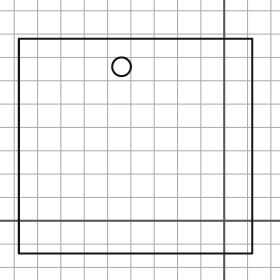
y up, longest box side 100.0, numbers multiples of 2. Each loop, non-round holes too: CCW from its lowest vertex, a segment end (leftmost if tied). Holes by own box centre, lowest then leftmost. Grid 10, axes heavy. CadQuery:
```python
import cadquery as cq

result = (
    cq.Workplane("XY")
    .moveTo(-88.0, -14.0)
    .lineTo(12.0, -14.0)
    .lineTo(12.0, 78.0)
    .lineTo(-88.0, 78.0)
    .close()
    .moveTo(-44.0, 66.0)
    .circle(4.0)
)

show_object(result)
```